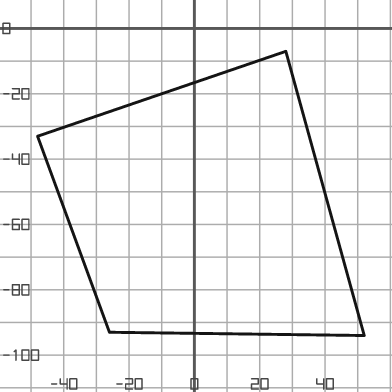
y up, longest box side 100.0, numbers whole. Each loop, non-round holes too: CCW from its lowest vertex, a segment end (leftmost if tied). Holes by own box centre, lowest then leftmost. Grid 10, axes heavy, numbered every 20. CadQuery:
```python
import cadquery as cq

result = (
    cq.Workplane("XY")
    .moveTo(52.0, -94.0)
    .lineTo(28.0, -7.0)
    .lineTo(-48.0, -33.0)
    .lineTo(-26.0, -93.0)
    .close()
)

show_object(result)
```